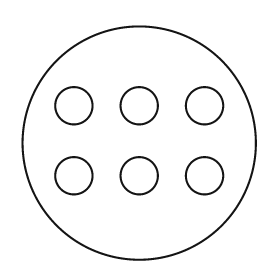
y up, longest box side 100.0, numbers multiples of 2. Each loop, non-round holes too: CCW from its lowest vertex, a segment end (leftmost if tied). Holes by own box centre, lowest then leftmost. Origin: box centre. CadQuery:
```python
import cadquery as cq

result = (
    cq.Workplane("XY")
    .moveTo(0.0, 0.0)
    .circle(50.0)
    .moveTo(-28.0, -14.0)
    .circle(8.0)
    .moveTo(0.0, -14.0)
    .circle(8.0)
    .moveTo(28.0, -14.0)
    .circle(8.0)
    .moveTo(-28.0, 16.0)
    .circle(8.0)
    .moveTo(0.0, 16.0)
    .circle(8.0)
    .moveTo(28.0, 16.0)
    .circle(8.0)
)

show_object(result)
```